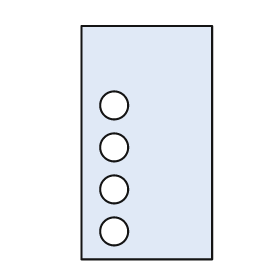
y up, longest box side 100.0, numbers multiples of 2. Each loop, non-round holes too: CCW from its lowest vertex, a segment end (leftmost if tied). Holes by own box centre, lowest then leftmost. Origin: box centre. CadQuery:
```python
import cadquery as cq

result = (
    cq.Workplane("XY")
    .moveTo(-28.0, -50.0)
    .lineTo(28.0, -50.0)
    .lineTo(28.0, 50.0)
    .lineTo(-28.0, 50.0)
    .close()
    .moveTo(-14.0, -38.0)
    .circle(6.0)
    .moveTo(-14.0, -20.0)
    .circle(6.0)
    .moveTo(-14.0, -2.0)
    .circle(6.0)
    .moveTo(-14.0, 16.0)
    .circle(6.0)
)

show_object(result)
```